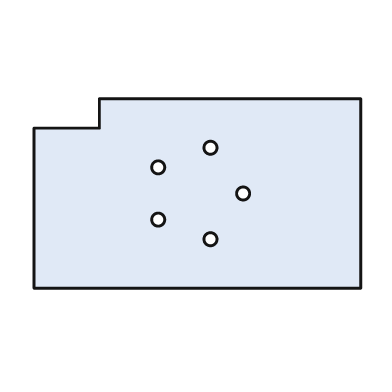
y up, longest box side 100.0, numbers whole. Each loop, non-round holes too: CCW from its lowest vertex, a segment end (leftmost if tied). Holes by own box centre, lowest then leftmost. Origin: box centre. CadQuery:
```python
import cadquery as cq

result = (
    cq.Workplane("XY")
    .moveTo(-50.0, -29.0)
    .lineTo(50.0, -29.0)
    .lineTo(50.0, 29.0)
    .lineTo(-30.0, 29.0)
    .lineTo(-30.0, 20.0)
    .lineTo(-50.0, 20.0)
    .close()
    .moveTo(4.0, -14.0)
    .circle(2.0)
    .moveTo(-12.0, -8.0)
    .circle(2.0)
    .moveTo(14.0, 0.0)
    .circle(2.0)
    .moveTo(-12.0, 8.0)
    .circle(2.0)
    .moveTo(4.0, 14.0)
    .circle(2.0)
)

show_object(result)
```